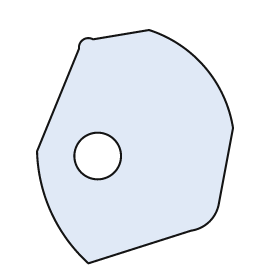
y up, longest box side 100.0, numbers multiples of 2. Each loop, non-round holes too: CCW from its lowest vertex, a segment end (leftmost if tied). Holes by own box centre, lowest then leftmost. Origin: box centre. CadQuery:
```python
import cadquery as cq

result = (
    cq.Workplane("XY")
    .moveTo(-20.0, -50.0)
    .lineTo(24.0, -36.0)
    .threePointArc((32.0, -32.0), (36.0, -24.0))
    .lineTo(42.0, 8.0)
    .threePointArc((30.0, 34.0), (6.0, 50.0))
    .lineTo(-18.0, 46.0)
    .threePointArc((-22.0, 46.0), (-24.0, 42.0))
    .lineTo(-42.0, -2.0)
    .threePointArc((-36.0, -28.0), (-20.0, -50.0))
    .close()
    .moveTo(-16.0, -4.0)
    .circle(10.0)
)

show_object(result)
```